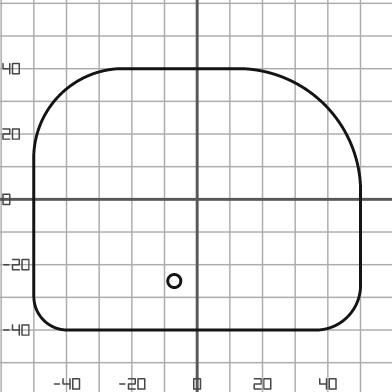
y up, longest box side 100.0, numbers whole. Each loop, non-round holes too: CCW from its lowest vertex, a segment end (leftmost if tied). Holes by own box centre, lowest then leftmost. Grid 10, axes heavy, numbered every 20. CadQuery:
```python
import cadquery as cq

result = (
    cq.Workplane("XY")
    .moveTo(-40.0, -40.0)
    .lineTo(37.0, -40.0)
    .threePointArc((46.0, -36.0), (50.0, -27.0))
    .lineTo(50.0, 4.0)
    .threePointArc((39.0, 29.0), (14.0, 40.0))
    .lineTo(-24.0, 40.0)
    .threePointArc((-42.0, 32.0), (-50.0, 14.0))
    .lineTo(-50.0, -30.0)
    .threePointArc((-47.0, -37.0), (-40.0, -40.0))
    .close()
    .moveTo(-7.0, -25.0)
    .circle(2.0)
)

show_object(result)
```